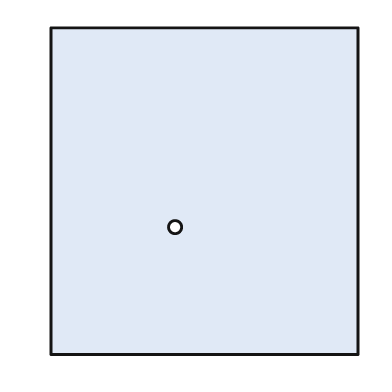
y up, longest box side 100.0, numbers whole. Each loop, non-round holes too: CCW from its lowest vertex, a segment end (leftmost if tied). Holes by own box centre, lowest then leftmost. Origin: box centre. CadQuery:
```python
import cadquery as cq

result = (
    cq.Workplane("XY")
    .moveTo(-47.0, -50.0)
    .lineTo(47.0, -50.0)
    .lineTo(47.0, 50.0)
    .lineTo(-47.0, 50.0)
    .close()
    .moveTo(-9.0, -11.0)
    .circle(2.0)
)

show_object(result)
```